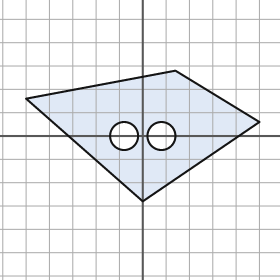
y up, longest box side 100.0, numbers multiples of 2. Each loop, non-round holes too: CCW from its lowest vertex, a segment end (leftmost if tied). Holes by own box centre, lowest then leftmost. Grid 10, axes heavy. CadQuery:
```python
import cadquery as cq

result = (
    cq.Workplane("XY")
    .moveTo(0.0, -28.0)
    .lineTo(50.0, 6.0)
    .lineTo(14.0, 28.0)
    .lineTo(-50.0, 16.0)
    .close()
    .moveTo(-8.0, 0.0)
    .circle(6.0)
    .moveTo(8.0, 0.0)
    .circle(6.0)
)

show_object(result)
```